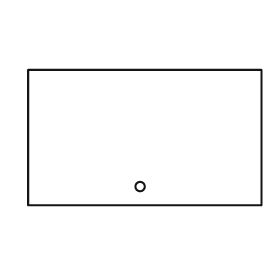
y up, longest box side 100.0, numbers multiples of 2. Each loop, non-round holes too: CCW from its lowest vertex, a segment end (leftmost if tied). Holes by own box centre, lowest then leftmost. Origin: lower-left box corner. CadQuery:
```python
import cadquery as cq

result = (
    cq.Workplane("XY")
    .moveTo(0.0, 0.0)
    .lineTo(100.0, 0.0)
    .lineTo(100.0, 58.0)
    .lineTo(0.0, 58.0)
    .close()
    .moveTo(48.0, 8.0)
    .circle(2.0)
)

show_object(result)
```